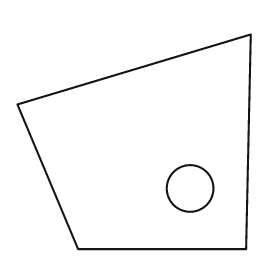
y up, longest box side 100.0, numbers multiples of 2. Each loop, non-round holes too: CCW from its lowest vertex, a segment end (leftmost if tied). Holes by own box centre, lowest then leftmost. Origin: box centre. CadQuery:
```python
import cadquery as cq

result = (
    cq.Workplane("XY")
    .moveTo(-24.0, -46.0)
    .lineTo(48.0, -46.0)
    .lineTo(50.0, 46.0)
    .lineTo(-50.0, 16.0)
    .close()
    .moveTo(24.0, -20.0)
    .circle(10.0)
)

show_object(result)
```